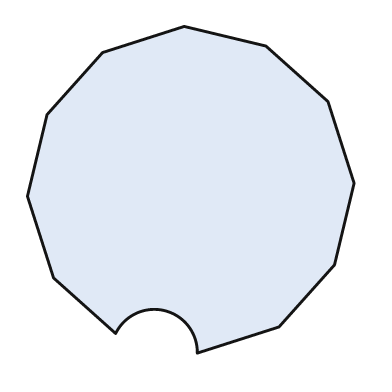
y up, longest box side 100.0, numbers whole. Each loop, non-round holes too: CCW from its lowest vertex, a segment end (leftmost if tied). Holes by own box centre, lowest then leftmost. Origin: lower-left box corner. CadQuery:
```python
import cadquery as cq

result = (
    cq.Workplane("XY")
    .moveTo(52.0, 0.0)
    .lineTo(77.0, 8.0)
    .lineTo(94.0, 27.0)
    .lineTo(100.0, 52.0)
    .lineTo(92.0, 77.0)
    .lineTo(73.0, 94.0)
    .lineTo(48.0, 100.0)
    .lineTo(23.0, 92.0)
    .lineTo(6.0, 73.0)
    .lineTo(0.0, 48.0)
    .lineTo(8.0, 23.0)
    .lineTo(27.0, 6.0)
    .threePointArc((42.0, 13.0), (52.0, 0.0))
    .close()
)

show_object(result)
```